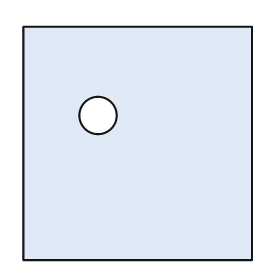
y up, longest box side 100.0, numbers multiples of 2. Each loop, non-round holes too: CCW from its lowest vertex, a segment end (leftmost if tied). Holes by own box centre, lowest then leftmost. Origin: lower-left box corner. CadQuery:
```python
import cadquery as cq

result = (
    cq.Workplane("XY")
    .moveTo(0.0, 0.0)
    .lineTo(98.0, 0.0)
    .lineTo(98.0, 100.0)
    .lineTo(0.0, 100.0)
    .close()
    .moveTo(32.0, 62.0)
    .circle(8.0)
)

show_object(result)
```